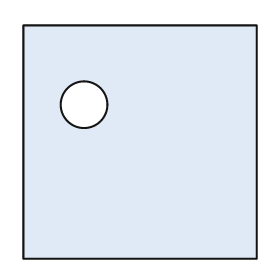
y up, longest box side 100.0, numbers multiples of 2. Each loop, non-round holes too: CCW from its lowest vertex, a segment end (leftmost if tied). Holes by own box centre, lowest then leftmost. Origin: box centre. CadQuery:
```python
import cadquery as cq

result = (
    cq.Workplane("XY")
    .moveTo(-50.0, -50.0)
    .lineTo(50.0, -50.0)
    .lineTo(50.0, 50.0)
    .lineTo(-50.0, 50.0)
    .close()
    .moveTo(-24.0, 16.0)
    .circle(10.0)
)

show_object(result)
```